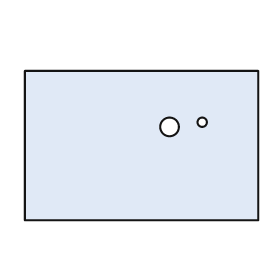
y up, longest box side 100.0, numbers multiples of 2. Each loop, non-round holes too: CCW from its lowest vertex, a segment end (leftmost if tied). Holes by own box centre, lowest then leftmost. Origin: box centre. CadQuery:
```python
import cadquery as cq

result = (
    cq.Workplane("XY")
    .moveTo(-50.0, -32.0)
    .lineTo(50.0, -32.0)
    .lineTo(50.0, 32.0)
    .lineTo(-50.0, 32.0)
    .close()
    .moveTo(12.0, 8.0)
    .circle(4.0)
    .moveTo(26.0, 10.0)
    .circle(2.0)
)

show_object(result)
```